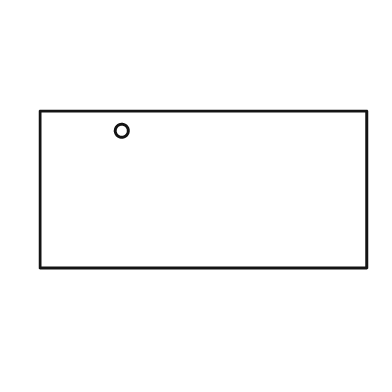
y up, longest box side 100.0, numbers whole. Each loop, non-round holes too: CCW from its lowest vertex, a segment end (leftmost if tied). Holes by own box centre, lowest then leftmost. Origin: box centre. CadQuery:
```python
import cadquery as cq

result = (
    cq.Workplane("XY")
    .moveTo(-50.0, -24.0)
    .lineTo(50.0, -24.0)
    .lineTo(50.0, 24.0)
    .lineTo(-50.0, 24.0)
    .close()
    .moveTo(-25.0, 18.0)
    .circle(2.0)
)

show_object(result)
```